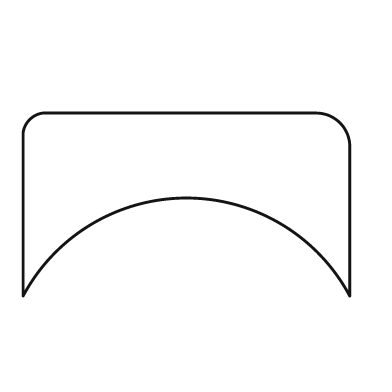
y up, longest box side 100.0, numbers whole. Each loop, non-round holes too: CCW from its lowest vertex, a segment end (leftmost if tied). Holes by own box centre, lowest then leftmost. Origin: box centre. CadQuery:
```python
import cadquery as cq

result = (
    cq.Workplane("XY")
    .moveTo(-50.0, -28.0)
    .threePointArc((0.0, 2.0), (50.0, -28.0))
    .lineTo(50.0, 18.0)
    .threePointArc((47.0, 25.0), (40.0, 28.0))
    .lineTo(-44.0, 28.0)
    .threePointArc((-48.0, 26.0), (-50.0, 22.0))
    .close()
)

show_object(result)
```